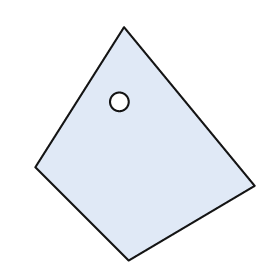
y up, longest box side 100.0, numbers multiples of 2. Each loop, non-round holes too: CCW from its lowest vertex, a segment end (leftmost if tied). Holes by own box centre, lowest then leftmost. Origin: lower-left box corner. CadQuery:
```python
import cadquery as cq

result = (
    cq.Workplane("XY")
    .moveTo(40.0, 0.0)
    .lineTo(94.0, 32.0)
    .lineTo(38.0, 100.0)
    .lineTo(0.0, 40.0)
    .close()
    .moveTo(36.0, 68.0)
    .circle(4.0)
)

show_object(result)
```